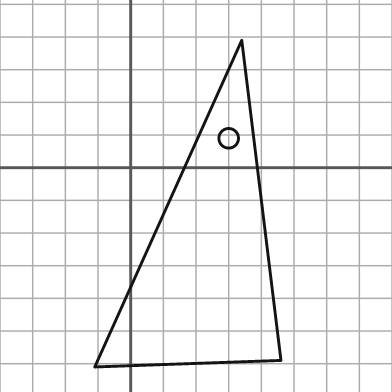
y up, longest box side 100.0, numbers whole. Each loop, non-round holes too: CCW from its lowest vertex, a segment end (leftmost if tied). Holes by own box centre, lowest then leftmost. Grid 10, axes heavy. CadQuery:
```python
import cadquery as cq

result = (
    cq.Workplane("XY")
    .moveTo(-11.0, -61.0)
    .lineTo(46.0, -59.0)
    .lineTo(34.0, 39.0)
    .close()
    .moveTo(30.0, 9.0)
    .circle(3.0)
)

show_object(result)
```